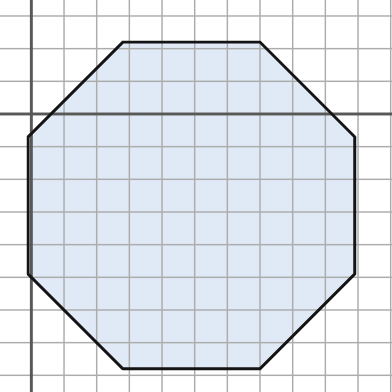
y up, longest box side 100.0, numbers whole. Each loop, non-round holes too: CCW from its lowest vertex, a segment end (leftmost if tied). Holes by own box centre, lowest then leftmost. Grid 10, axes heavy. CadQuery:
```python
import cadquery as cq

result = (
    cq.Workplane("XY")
    .moveTo(28.0, -78.0)
    .lineTo(70.0, -78.0)
    .lineTo(99.0, -49.0)
    .lineTo(99.0, -7.0)
    .lineTo(70.0, 22.0)
    .lineTo(28.0, 22.0)
    .lineTo(-1.0, -7.0)
    .lineTo(-1.0, -49.0)
    .close()
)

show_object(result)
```